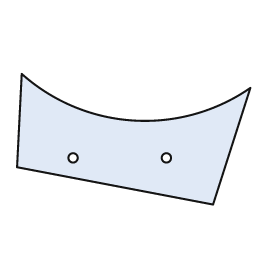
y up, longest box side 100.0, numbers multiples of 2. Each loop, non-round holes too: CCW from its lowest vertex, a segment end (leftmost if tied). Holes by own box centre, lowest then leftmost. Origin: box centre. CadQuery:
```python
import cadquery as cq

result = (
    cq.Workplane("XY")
    .moveTo(34.0, -28.0)
    .lineTo(50.0, 22.0)
    .threePointArc((0.0, 8.0), (-48.0, 28.0))
    .lineTo(-50.0, -12.0)
    .close()
    .moveTo(-26.0, -8.0)
    .circle(2.0)
    .moveTo(14.0, -8.0)
    .circle(2.0)
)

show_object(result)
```